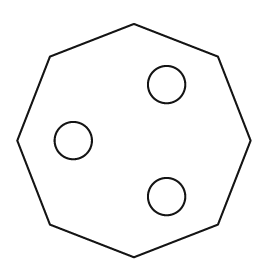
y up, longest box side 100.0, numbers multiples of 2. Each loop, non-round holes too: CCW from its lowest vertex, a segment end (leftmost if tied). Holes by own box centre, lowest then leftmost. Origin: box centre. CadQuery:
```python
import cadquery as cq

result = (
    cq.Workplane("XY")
    .moveTo(0.0, -50.0)
    .lineTo(36.0, -36.0)
    .lineTo(50.0, 0.0)
    .lineTo(36.0, 36.0)
    .lineTo(0.0, 50.0)
    .lineTo(-36.0, 36.0)
    .lineTo(-50.0, 0.0)
    .lineTo(-36.0, -36.0)
    .close()
    .moveTo(14.0, -24.0)
    .circle(8.0)
    .moveTo(-26.0, 0.0)
    .circle(8.0)
    .moveTo(14.0, 24.0)
    .circle(8.0)
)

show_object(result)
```